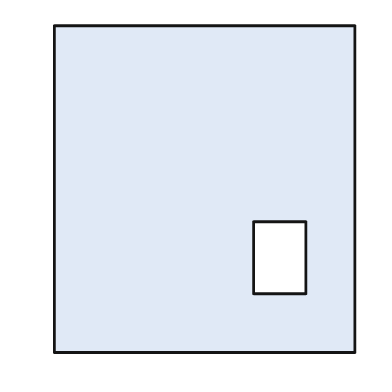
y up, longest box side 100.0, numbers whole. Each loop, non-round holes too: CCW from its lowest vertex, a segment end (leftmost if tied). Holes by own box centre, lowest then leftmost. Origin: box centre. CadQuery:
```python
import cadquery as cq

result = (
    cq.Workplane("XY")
    .moveTo(-46.0, -50.0)
    .lineTo(46.0, -50.0)
    .lineTo(46.0, 50.0)
    .lineTo(-46.0, 50.0)
    .close()
    .moveTo(15.0, -32.0)
    .lineTo(31.0, -32.0)
    .lineTo(31.0, -10.0)
    .lineTo(15.0, -10.0)
    .close()
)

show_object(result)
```